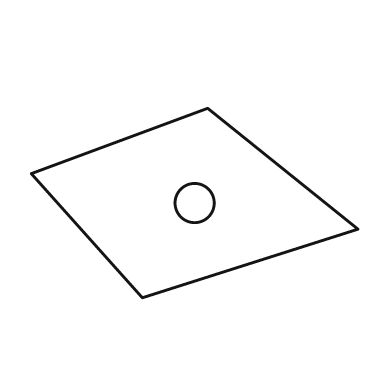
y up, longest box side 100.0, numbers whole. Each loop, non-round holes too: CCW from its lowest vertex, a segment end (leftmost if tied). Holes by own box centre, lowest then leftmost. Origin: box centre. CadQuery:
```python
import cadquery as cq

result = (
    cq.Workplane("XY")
    .moveTo(-16.0, -29.0)
    .lineTo(50.0, -8.0)
    .lineTo(4.0, 29.0)
    .lineTo(-50.0, 9.0)
    .close()
    .moveTo(0.0, 0.0)
    .circle(6.0)
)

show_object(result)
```